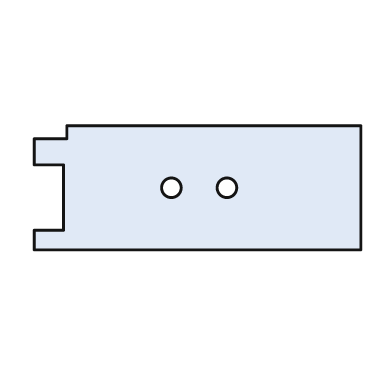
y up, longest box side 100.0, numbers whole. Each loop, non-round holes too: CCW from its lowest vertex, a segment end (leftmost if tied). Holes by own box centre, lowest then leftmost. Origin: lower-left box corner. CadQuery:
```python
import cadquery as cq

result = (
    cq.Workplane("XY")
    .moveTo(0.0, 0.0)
    .lineTo(100.0, 0.0)
    .lineTo(100.0, 38.0)
    .lineTo(10.0, 38.0)
    .lineTo(10.0, 34.0)
    .lineTo(0.0, 34.0)
    .lineTo(0.0, 26.0)
    .lineTo(9.0, 26.0)
    .lineTo(9.0, 6.0)
    .lineTo(0.0, 6.0)
    .close()
    .moveTo(42.0, 19.0)
    .circle(3.0)
    .moveTo(59.0, 19.0)
    .circle(3.0)
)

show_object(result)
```